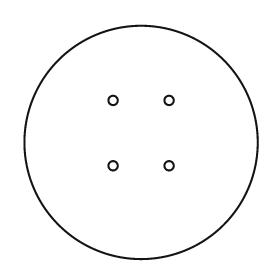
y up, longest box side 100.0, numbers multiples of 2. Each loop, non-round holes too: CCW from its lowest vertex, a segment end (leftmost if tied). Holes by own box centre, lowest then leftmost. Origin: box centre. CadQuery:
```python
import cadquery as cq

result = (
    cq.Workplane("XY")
    .moveTo(0.0, 0.0)
    .circle(50.0)
    .moveTo(-12.0, -10.0)
    .circle(2.0)
    .moveTo(12.0, -10.0)
    .circle(2.0)
    .moveTo(-12.0, 18.0)
    .circle(2.0)
    .moveTo(12.0, 18.0)
    .circle(2.0)
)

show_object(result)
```